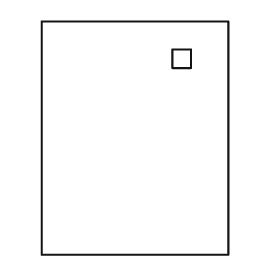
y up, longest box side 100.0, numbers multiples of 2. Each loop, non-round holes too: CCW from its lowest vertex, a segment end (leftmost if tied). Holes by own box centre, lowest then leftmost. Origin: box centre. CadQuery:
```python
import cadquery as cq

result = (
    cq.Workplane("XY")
    .moveTo(-40.0, -50.0)
    .lineTo(40.0, -50.0)
    .lineTo(40.0, 50.0)
    .lineTo(-40.0, 50.0)
    .close()
    .moveTo(16.0, 30.0)
    .lineTo(24.0, 30.0)
    .lineTo(24.0, 38.0)
    .lineTo(16.0, 38.0)
    .close()
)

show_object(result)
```